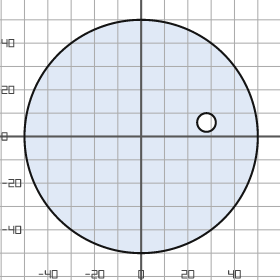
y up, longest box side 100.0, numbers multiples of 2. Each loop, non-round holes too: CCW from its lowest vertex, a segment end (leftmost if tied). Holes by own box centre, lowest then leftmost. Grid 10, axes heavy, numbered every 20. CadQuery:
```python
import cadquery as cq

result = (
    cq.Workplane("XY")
    .moveTo(0.0, 0.0)
    .circle(50.0)
    .moveTo(28.0, 6.0)
    .circle(4.0)
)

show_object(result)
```